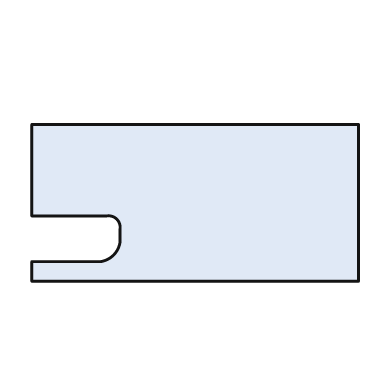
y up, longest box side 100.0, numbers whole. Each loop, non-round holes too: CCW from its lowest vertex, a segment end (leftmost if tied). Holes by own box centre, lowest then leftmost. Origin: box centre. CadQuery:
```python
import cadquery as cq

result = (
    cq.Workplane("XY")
    .moveTo(-50.0, -24.0)
    .lineTo(50.0, -24.0)
    .lineTo(50.0, 24.0)
    .lineTo(-50.0, 24.0)
    .lineTo(-50.0, -4.0)
    .lineTo(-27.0, -4.0)
    .threePointArc((-24.0, -5.0), (-23.0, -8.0))
    .lineTo(-23.0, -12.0)
    .threePointArc((-25.0, -16.0), (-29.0, -18.0))
    .lineTo(-50.0, -18.0)
    .close()
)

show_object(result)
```